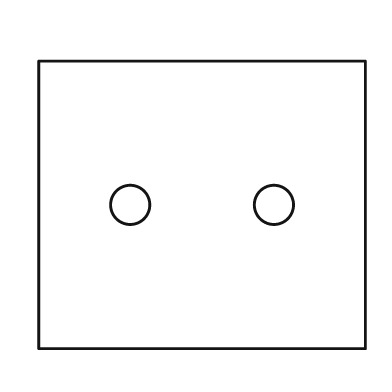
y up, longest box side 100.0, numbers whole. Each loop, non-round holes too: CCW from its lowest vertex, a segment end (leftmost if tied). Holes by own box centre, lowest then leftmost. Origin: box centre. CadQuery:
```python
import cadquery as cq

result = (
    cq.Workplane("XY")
    .moveTo(-50.0, -44.0)
    .lineTo(50.0, -44.0)
    .lineTo(50.0, 44.0)
    .lineTo(-50.0, 44.0)
    .close()
    .moveTo(-22.0, 0.0)
    .circle(6.0)
    .moveTo(22.0, 0.0)
    .circle(6.0)
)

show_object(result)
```